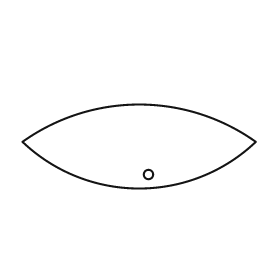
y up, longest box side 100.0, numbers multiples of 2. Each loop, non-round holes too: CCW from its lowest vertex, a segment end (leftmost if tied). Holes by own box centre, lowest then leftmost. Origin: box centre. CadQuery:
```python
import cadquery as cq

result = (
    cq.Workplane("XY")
    .moveTo(-50.0, 2.0)
    .threePointArc((0.0, -18.0), (50.0, 2.0))
    .threePointArc((0.0, 18.0), (-50.0, 2.0))
    .close()
    .moveTo(4.0, -12.0)
    .circle(2.0)
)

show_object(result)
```